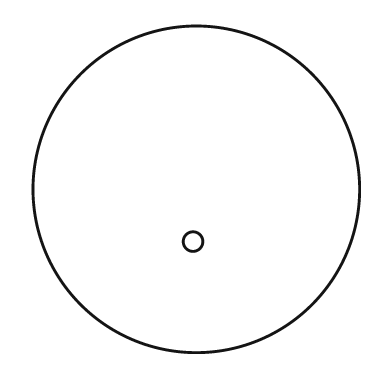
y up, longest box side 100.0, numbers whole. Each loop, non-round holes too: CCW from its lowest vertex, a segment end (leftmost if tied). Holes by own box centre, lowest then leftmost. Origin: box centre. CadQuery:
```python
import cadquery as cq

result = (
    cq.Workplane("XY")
    .moveTo(0.0, 0.0)
    .circle(50.0)
    .moveTo(-1.0, -16.0)
    .circle(3.0)
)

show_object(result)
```